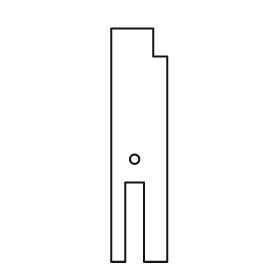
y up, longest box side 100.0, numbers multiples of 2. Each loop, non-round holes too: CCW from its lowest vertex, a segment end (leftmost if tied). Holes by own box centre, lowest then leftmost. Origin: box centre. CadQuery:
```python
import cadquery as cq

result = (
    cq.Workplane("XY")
    .moveTo(-12.0, -50.0)
    .lineTo(-6.0, -50.0)
    .lineTo(-6.0, -16.0)
    .lineTo(2.0, -16.0)
    .lineTo(2.0, -50.0)
    .lineTo(12.0, -50.0)
    .lineTo(12.0, 38.0)
    .lineTo(6.0, 38.0)
    .lineTo(6.0, 50.0)
    .lineTo(-12.0, 50.0)
    .close()
    .moveTo(-2.0, -6.0)
    .circle(2.0)
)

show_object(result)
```